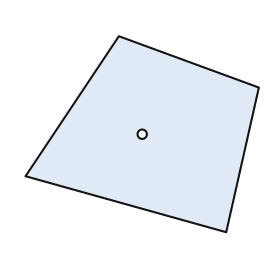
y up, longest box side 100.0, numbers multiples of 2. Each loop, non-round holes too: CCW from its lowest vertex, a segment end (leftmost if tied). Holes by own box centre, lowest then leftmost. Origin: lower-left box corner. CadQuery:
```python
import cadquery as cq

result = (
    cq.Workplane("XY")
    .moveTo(86.0, 0.0)
    .lineTo(100.0, 62.0)
    .lineTo(40.0, 84.0)
    .lineTo(0.0, 24.0)
    .close()
    .moveTo(50.0, 42.0)
    .circle(2.0)
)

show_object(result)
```